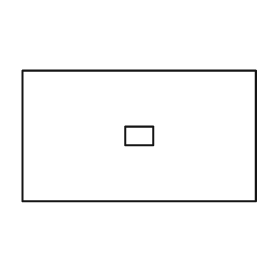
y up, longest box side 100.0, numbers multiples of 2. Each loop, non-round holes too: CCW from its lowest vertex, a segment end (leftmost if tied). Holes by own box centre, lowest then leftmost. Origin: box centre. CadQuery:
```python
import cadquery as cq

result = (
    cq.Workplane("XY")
    .moveTo(-50.0, -28.0)
    .lineTo(50.0, -28.0)
    .lineTo(50.0, 28.0)
    .lineTo(-50.0, 28.0)
    .close()
    .moveTo(-6.0, -4.0)
    .lineTo(6.0, -4.0)
    .lineTo(6.0, 4.0)
    .lineTo(-6.0, 4.0)
    .close()
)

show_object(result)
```